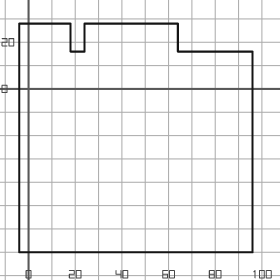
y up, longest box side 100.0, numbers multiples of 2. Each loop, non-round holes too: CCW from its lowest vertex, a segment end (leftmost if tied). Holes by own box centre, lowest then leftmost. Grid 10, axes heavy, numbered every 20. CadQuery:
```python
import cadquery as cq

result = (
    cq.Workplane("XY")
    .moveTo(-4.0, -70.0)
    .lineTo(96.0, -70.0)
    .lineTo(96.0, 16.0)
    .lineTo(64.0, 16.0)
    .lineTo(64.0, 28.0)
    .lineTo(24.0, 28.0)
    .lineTo(24.0, 16.0)
    .lineTo(18.0, 16.0)
    .lineTo(18.0, 28.0)
    .lineTo(-4.0, 28.0)
    .close()
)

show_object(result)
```